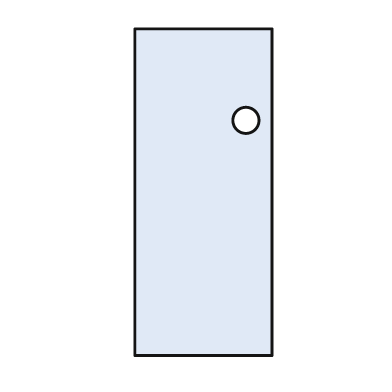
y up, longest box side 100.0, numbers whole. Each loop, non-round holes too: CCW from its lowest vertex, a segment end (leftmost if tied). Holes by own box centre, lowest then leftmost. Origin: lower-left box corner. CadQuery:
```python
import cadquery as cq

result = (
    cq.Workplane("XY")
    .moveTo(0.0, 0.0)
    .lineTo(42.0, 0.0)
    .lineTo(42.0, 100.0)
    .lineTo(0.0, 100.0)
    .close()
    .moveTo(34.0, 72.0)
    .circle(4.0)
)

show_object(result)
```